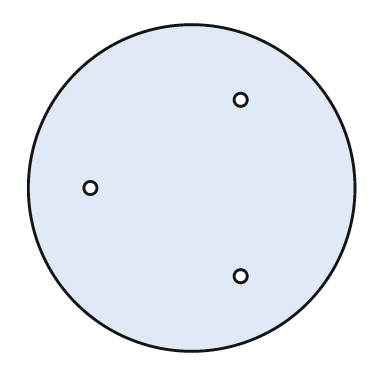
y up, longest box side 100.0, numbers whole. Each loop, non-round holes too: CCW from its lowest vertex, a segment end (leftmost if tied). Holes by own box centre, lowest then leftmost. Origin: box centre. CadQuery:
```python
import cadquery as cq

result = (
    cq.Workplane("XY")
    .moveTo(0.0, 0.0)
    .circle(50.0)
    .moveTo(15.0, -27.0)
    .circle(2.0)
    .moveTo(-31.0, 0.0)
    .circle(2.0)
    .moveTo(15.0, 27.0)
    .circle(2.0)
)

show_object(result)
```